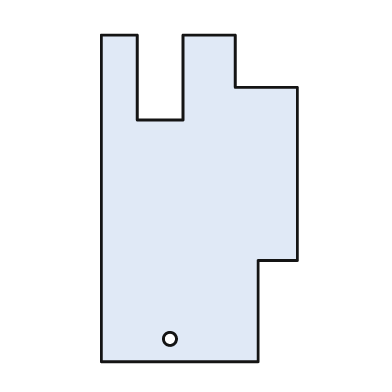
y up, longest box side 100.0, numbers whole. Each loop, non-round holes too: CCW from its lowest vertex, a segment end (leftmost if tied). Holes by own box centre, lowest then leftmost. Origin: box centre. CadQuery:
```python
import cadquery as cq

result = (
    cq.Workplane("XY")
    .moveTo(-30.0, -50.0)
    .lineTo(18.0, -50.0)
    .lineTo(18.0, -19.0)
    .lineTo(30.0, -19.0)
    .lineTo(30.0, 34.0)
    .lineTo(11.0, 34.0)
    .lineTo(11.0, 50.0)
    .lineTo(-5.0, 50.0)
    .lineTo(-5.0, 24.0)
    .lineTo(-19.0, 24.0)
    .lineTo(-19.0, 50.0)
    .lineTo(-30.0, 50.0)
    .close()
    .moveTo(-9.0, -43.0)
    .circle(2.0)
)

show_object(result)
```